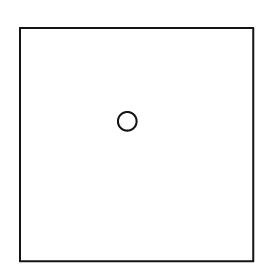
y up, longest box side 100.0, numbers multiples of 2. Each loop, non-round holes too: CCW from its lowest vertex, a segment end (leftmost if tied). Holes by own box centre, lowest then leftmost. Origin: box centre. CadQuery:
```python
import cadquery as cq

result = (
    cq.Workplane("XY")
    .moveTo(-50.0, -50.0)
    .lineTo(50.0, -50.0)
    .lineTo(50.0, 50.0)
    .lineTo(-50.0, 50.0)
    .close()
    .moveTo(-4.0, 10.0)
    .circle(4.0)
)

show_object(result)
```